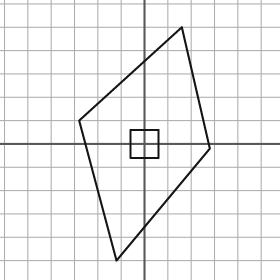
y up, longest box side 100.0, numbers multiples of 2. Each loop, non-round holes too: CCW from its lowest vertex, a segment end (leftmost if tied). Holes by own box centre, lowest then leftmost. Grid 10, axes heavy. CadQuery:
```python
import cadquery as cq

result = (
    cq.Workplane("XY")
    .moveTo(-12.0, -50.0)
    .lineTo(28.0, -2.0)
    .lineTo(16.0, 50.0)
    .lineTo(-28.0, 10.0)
    .close()
    .moveTo(-6.0, -6.0)
    .lineTo(6.0, -6.0)
    .lineTo(6.0, 6.0)
    .lineTo(-6.0, 6.0)
    .close()
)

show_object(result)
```